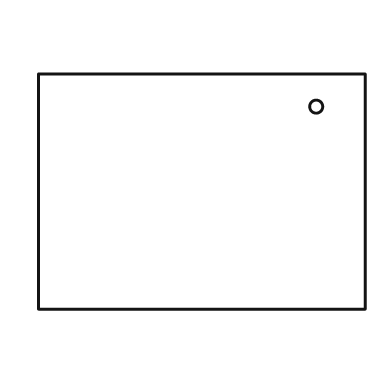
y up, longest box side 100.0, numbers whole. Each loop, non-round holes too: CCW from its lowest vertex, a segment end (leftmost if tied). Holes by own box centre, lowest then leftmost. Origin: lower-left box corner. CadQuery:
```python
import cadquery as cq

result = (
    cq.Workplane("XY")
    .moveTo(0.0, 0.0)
    .lineTo(100.0, 0.0)
    .lineTo(100.0, 72.0)
    .lineTo(0.0, 72.0)
    .close()
    .moveTo(85.0, 62.0)
    .circle(2.0)
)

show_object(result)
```